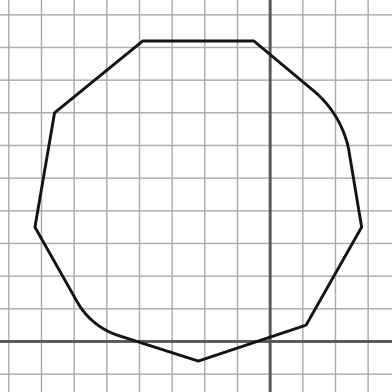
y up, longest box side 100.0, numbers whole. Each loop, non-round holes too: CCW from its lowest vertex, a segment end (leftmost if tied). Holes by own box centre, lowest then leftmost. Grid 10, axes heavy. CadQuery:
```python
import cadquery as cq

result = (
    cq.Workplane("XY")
    .moveTo(-22.0, -6.0)
    .lineTo(11.0, 5.0)
    .lineTo(28.0, 35.0)
    .lineTo(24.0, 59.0)
    .threePointArc((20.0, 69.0), (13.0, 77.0))
    .lineTo(-5.0, 92.0)
    .lineTo(-39.0, 92.0)
    .lineTo(-66.0, 70.0)
    .lineTo(-72.0, 35.0)
    .lineTo(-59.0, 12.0)
    .threePointArc((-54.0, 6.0), (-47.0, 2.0))
    .close()
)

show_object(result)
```